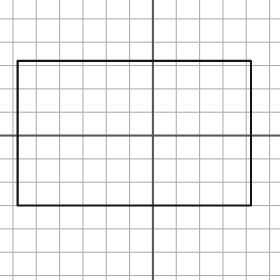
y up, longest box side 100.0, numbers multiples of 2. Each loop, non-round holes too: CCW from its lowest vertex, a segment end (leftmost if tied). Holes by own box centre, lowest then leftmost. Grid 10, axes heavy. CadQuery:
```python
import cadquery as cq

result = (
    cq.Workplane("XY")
    .moveTo(-58.0, -30.0)
    .lineTo(42.0, -30.0)
    .lineTo(42.0, 32.0)
    .lineTo(-58.0, 32.0)
    .close()
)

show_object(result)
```